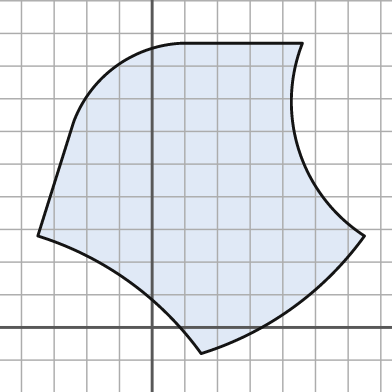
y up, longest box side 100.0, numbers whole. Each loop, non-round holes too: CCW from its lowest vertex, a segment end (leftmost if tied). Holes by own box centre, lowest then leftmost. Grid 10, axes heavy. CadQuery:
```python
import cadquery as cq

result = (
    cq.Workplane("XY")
    .moveTo(15.0, -8.0)
    .threePointArc((43.0, 6.0), (65.0, 28.0))
    .threePointArc((45.0, 54.0), (46.0, 87.0))
    .lineTo(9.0, 87.0)
    .threePointArc((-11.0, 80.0), (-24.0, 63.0))
    .lineTo(-35.0, 28.0)
    .threePointArc((-7.0, 14.0), (15.0, -8.0))
    .close()
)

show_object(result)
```